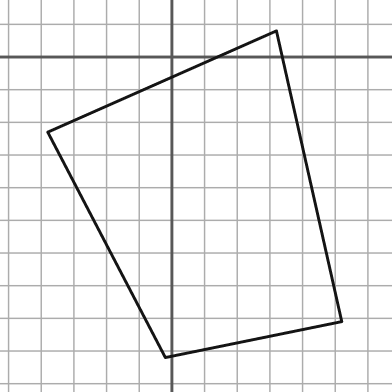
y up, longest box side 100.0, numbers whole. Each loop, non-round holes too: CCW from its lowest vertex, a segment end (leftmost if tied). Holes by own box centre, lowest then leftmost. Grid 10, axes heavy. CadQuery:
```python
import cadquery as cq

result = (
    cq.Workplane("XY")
    .moveTo(-2.0, -92.0)
    .lineTo(52.0, -81.0)
    .lineTo(32.0, 8.0)
    .lineTo(-38.0, -23.0)
    .close()
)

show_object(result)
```